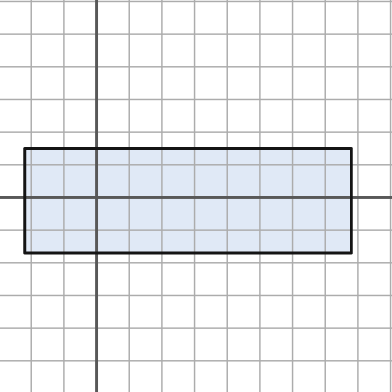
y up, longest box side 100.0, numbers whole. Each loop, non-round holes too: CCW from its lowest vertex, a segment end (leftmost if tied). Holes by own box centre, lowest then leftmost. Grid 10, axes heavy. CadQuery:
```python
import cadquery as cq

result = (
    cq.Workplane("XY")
    .moveTo(-22.0, -17.0)
    .lineTo(78.0, -17.0)
    .lineTo(78.0, 15.0)
    .lineTo(-22.0, 15.0)
    .close()
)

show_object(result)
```